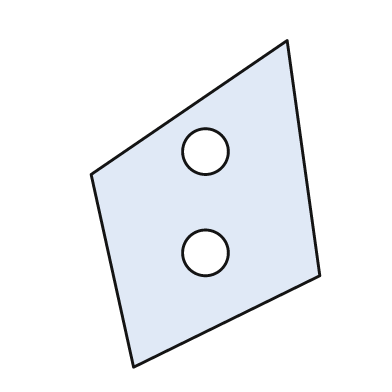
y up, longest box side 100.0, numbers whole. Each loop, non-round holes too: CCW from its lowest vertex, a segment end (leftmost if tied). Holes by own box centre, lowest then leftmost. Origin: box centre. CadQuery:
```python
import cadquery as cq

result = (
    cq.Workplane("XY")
    .moveTo(-22.0, -50.0)
    .lineTo(35.0, -22.0)
    .lineTo(25.0, 50.0)
    .lineTo(-35.0, 9.0)
    .close()
    .moveTo(0.0, -15.0)
    .circle(7.0)
    .moveTo(0.0, 16.0)
    .circle(7.0)
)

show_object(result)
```